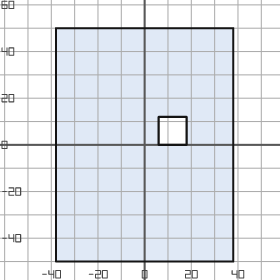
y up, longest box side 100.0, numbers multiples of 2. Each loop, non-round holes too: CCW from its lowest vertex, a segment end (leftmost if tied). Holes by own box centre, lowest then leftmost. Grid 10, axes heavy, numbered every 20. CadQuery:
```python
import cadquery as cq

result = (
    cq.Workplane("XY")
    .moveTo(-38.0, -50.0)
    .lineTo(38.0, -50.0)
    .lineTo(38.0, 50.0)
    .lineTo(-38.0, 50.0)
    .close()
    .moveTo(6.0, 0.0)
    .lineTo(18.0, 0.0)
    .lineTo(18.0, 12.0)
    .lineTo(6.0, 12.0)
    .close()
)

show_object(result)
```